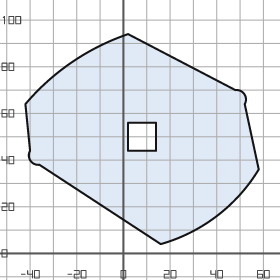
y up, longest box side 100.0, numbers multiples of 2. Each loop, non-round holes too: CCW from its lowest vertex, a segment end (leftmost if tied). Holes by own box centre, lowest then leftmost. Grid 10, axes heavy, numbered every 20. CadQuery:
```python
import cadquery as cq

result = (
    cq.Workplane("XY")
    .moveTo(16.0, 4.0)
    .threePointArc((40.0, 16.0), (58.0, 36.0))
    .lineTo(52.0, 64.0)
    .threePointArc((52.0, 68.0), (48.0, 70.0))
    .lineTo(2.0, 94.0)
    .threePointArc((-22.0, 82.0), (-42.0, 64.0))
    .lineTo(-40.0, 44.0)
    .threePointArc((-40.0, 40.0), (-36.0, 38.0))
    .close()
    .moveTo(2.0, 44.0)
    .lineTo(14.0, 44.0)
    .lineTo(14.0, 56.0)
    .lineTo(2.0, 56.0)
    .close()
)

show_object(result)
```